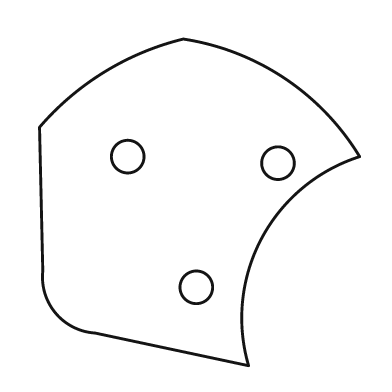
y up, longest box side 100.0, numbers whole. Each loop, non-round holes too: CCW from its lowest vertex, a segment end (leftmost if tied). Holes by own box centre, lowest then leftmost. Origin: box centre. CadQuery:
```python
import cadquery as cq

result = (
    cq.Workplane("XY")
    .moveTo(15.0, -50.0)
    .threePointArc((19.0, -11.0), (49.0, 14.0))
    .threePointArc((26.0, 38.0), (-5.0, 50.0))
    .threePointArc((-29.0, 40.0), (-49.0, 23.0))
    .lineTo(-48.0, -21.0)
    .threePointArc((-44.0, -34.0), (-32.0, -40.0))
    .close()
    .moveTo(-1.0, -26.0)
    .circle(5.0)
    .moveTo(24.0, 12.0)
    .circle(5.0)
    .moveTo(-22.0, 14.0)
    .circle(5.0)
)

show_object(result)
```